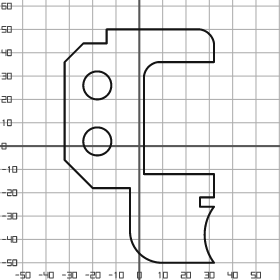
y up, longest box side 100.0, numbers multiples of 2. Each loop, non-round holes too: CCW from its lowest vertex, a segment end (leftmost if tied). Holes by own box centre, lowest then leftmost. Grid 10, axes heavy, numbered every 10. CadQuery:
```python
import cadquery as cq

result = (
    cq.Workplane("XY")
    .moveTo(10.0, -50.0)
    .lineTo(32.0, -50.0)
    .threePointArc((28.0, -38.0), (32.0, -26.0))
    .lineTo(26.0, -26.0)
    .lineTo(26.0, -22.0)
    .lineTo(32.0, -22.0)
    .lineTo(32.0, -12.0)
    .lineTo(2.0, -12.0)
    .lineTo(2.0, 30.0)
    .threePointArc((4.0, 34.0), (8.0, 36.0))
    .lineTo(32.0, 36.0)
    .lineTo(32.0, 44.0)
    .threePointArc((30.0, 48.0), (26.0, 50.0))
    .lineTo(-14.0, 50.0)
    .lineTo(-14.0, 44.0)
    .lineTo(-24.0, 44.0)
    .lineTo(-32.0, 36.0)
    .lineTo(-32.0, -6.0)
    .lineTo(-20.0, -18.0)
    .lineTo(-4.0, -18.0)
    .lineTo(-4.0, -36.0)
    .threePointArc((0.0, -46.0), (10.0, -50.0))
    .close()
    .moveTo(-18.0, 2.0)
    .circle(6.0)
    .moveTo(-18.0, 26.0)
    .circle(6.0)
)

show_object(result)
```